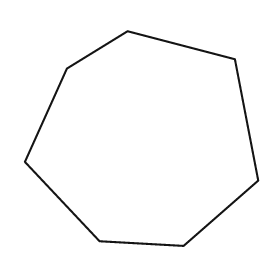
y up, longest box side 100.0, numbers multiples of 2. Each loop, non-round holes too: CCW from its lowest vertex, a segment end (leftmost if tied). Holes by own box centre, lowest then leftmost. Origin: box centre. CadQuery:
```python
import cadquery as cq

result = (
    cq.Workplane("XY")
    .moveTo(18.0, -46.0)
    .lineTo(50.0, -18.0)
    .lineTo(40.0, 34.0)
    .lineTo(-6.0, 46.0)
    .lineTo(-32.0, 30.0)
    .lineTo(-50.0, -10.0)
    .lineTo(-18.0, -44.0)
    .close()
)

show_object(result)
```